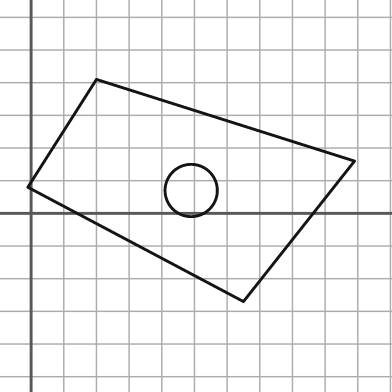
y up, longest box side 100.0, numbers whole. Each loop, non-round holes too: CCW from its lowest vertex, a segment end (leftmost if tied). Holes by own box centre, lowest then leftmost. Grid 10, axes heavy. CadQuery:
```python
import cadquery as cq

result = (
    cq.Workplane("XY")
    .moveTo(65.0, -27.0)
    .lineTo(99.0, 16.0)
    .lineTo(20.0, 41.0)
    .lineTo(-1.0, 8.0)
    .close()
    .moveTo(49.0, 7.0)
    .circle(8.0)
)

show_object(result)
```